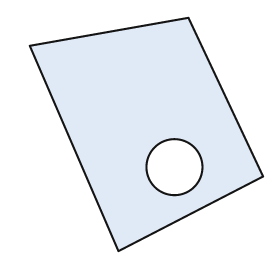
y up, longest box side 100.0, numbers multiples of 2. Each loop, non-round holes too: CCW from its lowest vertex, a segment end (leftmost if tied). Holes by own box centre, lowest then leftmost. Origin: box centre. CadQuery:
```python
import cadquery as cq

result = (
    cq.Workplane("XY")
    .moveTo(-12.0, -50.0)
    .lineTo(50.0, -18.0)
    .lineTo(18.0, 50.0)
    .lineTo(-50.0, 38.0)
    .close()
    .moveTo(12.0, -14.0)
    .circle(12.0)
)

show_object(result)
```